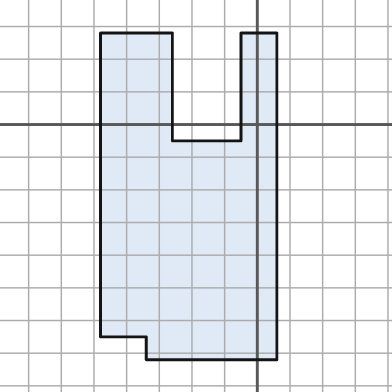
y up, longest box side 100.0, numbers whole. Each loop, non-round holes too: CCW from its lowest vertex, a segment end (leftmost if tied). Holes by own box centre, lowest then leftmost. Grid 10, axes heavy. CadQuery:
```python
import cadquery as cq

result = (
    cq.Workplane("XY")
    .moveTo(-34.0, -72.0)
    .lineTo(6.0, -72.0)
    .lineTo(6.0, 28.0)
    .lineTo(-5.0, 28.0)
    .lineTo(-5.0, -5.0)
    .lineTo(-26.0, -5.0)
    .lineTo(-26.0, 28.0)
    .lineTo(-48.0, 28.0)
    .lineTo(-48.0, -65.0)
    .lineTo(-34.0, -65.0)
    .close()
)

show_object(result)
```